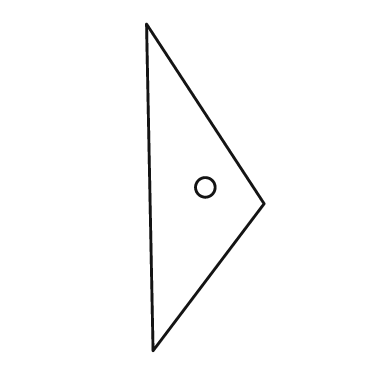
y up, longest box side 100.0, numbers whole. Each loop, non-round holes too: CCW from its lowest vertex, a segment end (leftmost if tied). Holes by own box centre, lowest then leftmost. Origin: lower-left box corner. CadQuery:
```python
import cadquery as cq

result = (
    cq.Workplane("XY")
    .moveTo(2.0, 0.0)
    .lineTo(36.0, 45.0)
    .lineTo(0.0, 100.0)
    .close()
    .moveTo(18.0, 50.0)
    .circle(3.0)
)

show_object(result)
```